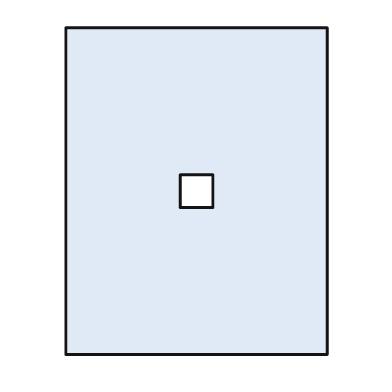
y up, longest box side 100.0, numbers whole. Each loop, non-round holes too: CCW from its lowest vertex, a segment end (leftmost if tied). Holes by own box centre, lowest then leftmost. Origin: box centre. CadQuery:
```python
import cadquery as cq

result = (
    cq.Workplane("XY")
    .moveTo(-40.0, -50.0)
    .lineTo(40.0, -50.0)
    .lineTo(40.0, 50.0)
    .lineTo(-40.0, 50.0)
    .close()
    .moveTo(-5.0, -5.0)
    .lineTo(5.0, -5.0)
    .lineTo(5.0, 5.0)
    .lineTo(-5.0, 5.0)
    .close()
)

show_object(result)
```